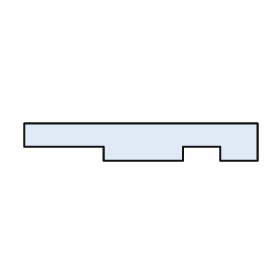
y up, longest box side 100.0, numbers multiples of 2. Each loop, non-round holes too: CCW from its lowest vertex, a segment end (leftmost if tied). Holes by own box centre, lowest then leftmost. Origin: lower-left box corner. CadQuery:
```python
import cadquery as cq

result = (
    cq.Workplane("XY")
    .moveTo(34.0, 0.0)
    .lineTo(68.0, 0.0)
    .lineTo(68.0, 6.0)
    .lineTo(84.0, 6.0)
    .lineTo(84.0, 0.0)
    .lineTo(100.0, 0.0)
    .lineTo(100.0, 16.0)
    .lineTo(0.0, 16.0)
    .lineTo(0.0, 6.0)
    .lineTo(34.0, 6.0)
    .close()
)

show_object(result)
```